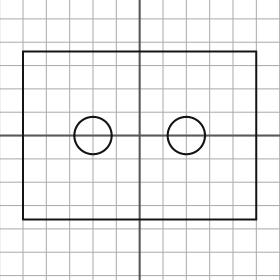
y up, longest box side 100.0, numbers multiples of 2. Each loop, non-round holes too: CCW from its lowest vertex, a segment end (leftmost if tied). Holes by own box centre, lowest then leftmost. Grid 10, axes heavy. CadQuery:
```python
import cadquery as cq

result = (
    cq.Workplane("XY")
    .moveTo(-50.0, -36.0)
    .lineTo(50.0, -36.0)
    .lineTo(50.0, 36.0)
    .lineTo(-50.0, 36.0)
    .close()
    .moveTo(-20.0, 0.0)
    .circle(8.0)
    .moveTo(20.0, 0.0)
    .circle(8.0)
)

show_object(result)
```